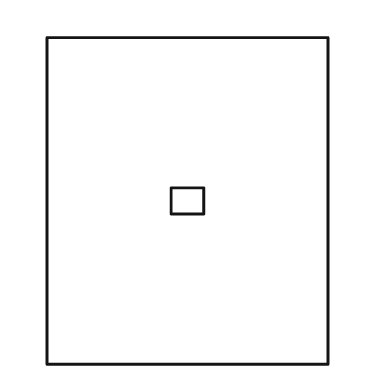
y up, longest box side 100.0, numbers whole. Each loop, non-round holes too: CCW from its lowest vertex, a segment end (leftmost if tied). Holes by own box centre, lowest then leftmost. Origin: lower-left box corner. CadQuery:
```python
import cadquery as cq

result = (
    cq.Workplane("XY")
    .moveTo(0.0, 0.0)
    .lineTo(86.0, 0.0)
    .lineTo(86.0, 100.0)
    .lineTo(0.0, 100.0)
    .close()
    .moveTo(38.0, 46.0)
    .lineTo(48.0, 46.0)
    .lineTo(48.0, 54.0)
    .lineTo(38.0, 54.0)
    .close()
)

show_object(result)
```